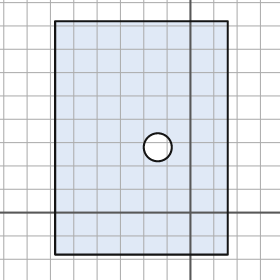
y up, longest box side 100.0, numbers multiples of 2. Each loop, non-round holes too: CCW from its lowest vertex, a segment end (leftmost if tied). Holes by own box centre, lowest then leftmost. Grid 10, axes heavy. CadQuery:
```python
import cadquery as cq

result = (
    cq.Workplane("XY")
    .moveTo(-58.0, -18.0)
    .lineTo(16.0, -18.0)
    .lineTo(16.0, 82.0)
    .lineTo(-58.0, 82.0)
    .close()
    .moveTo(-14.0, 28.0)
    .circle(6.0)
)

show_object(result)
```